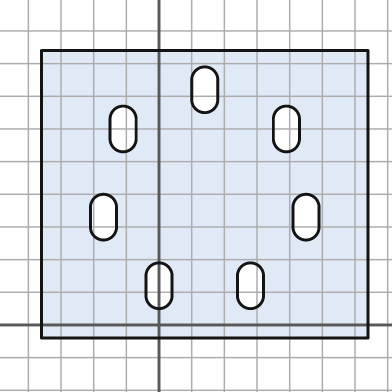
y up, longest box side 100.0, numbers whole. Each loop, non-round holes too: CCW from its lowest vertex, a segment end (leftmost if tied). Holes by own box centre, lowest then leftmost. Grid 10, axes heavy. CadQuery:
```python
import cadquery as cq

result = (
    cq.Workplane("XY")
    .moveTo(-36.0, -4.0)
    .lineTo(64.0, -4.0)
    .lineTo(64.0, 84.0)
    .lineTo(-36.0, 84.0)
    .close()
    .moveTo(-4.0, 9.0)
    .threePointArc((0.0, 5.0), (4.0, 9.0))
    .lineTo(4.0, 15.0)
    .threePointArc((0.0, 19.0), (-4.0, 15.0))
    .close()
    .moveTo(24.0, 9.0)
    .threePointArc((28.0, 5.0), (32.0, 9.0))
    .lineTo(32.0, 15.0)
    .threePointArc((28.0, 19.0), (24.0, 15.0))
    .close()
    .moveTo(-21.0, 30.0)
    .threePointArc((-17.0, 26.0), (-13.0, 30.0))
    .lineTo(-13.0, 36.0)
    .threePointArc((-17.0, 40.0), (-21.0, 36.0))
    .close()
    .moveTo(41.0, 30.0)
    .threePointArc((45.0, 26.0), (49.0, 30.0))
    .lineTo(49.0, 36.0)
    .threePointArc((45.0, 40.0), (41.0, 36.0))
    .close()
    .moveTo(-15.0, 57.0)
    .threePointArc((-11.0, 53.0), (-7.0, 57.0))
    .lineTo(-7.0, 63.0)
    .threePointArc((-11.0, 67.0), (-15.0, 63.0))
    .close()
    .moveTo(35.0, 57.0)
    .threePointArc((39.0, 53.0), (43.0, 57.0))
    .lineTo(43.0, 63.0)
    .threePointArc((39.0, 67.0), (35.0, 63.0))
    .close()
    .moveTo(10.0, 69.0)
    .threePointArc((14.0, 65.0), (18.0, 69.0))
    .lineTo(18.0, 75.0)
    .threePointArc((14.0, 79.0), (10.0, 75.0))
    .close()
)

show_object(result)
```